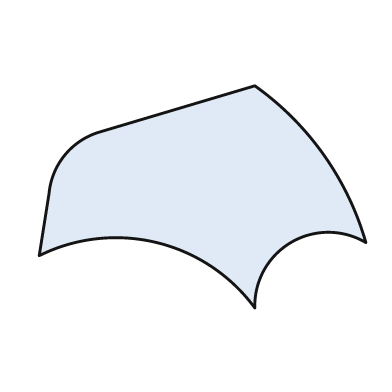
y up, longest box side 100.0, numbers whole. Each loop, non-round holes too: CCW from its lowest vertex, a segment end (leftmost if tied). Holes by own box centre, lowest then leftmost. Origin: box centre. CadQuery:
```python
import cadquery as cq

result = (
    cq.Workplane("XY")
    .moveTo(16.0, -34.0)
    .threePointArc((27.0, -14.0), (50.0, -14.0))
    .threePointArc((37.0, 13.0), (16.0, 34.0))
    .lineTo(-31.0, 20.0)
    .threePointArc((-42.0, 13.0), (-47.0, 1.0))
    .lineTo(-50.0, -18.0)
    .threePointArc((-14.0, -14.0), (16.0, -34.0))
    .close()
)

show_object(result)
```